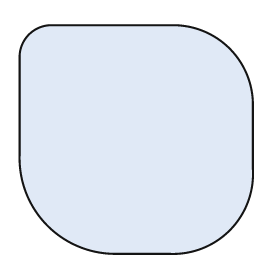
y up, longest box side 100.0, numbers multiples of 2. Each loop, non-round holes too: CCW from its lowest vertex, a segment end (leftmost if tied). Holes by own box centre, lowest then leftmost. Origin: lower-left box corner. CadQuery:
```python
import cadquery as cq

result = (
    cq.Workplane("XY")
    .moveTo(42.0, 0.0)
    .lineTo(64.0, 0.0)
    .threePointArc((90.0, 10.0), (100.0, 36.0))
    .lineTo(100.0, 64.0)
    .threePointArc((90.0, 88.0), (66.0, 98.0))
    .lineTo(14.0, 98.0)
    .threePointArc((4.0, 94.0), (0.0, 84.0))
    .lineTo(0.0, 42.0)
    .threePointArc((12.0, 12.0), (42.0, 0.0))
    .close()
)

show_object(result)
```